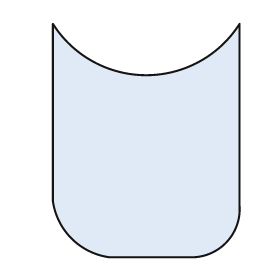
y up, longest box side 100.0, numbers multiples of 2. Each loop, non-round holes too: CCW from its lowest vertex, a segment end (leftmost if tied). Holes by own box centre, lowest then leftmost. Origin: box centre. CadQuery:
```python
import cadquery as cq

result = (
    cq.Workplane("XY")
    .moveTo(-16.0, -50.0)
    .lineTo(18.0, -50.0)
    .threePointArc((34.0, -44.0), (40.0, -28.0))
    .lineTo(40.0, 50.0)
    .threePointArc((0.0, 28.0), (-40.0, 50.0))
    .lineTo(-40.0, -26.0)
    .threePointArc((-32.0, -42.0), (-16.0, -50.0))
    .close()
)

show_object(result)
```